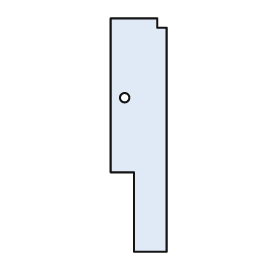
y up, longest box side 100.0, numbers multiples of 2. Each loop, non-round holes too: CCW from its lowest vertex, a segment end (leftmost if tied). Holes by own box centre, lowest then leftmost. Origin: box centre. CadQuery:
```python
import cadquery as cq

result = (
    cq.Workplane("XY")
    .moveTo(-2.0, -50.0)
    .lineTo(12.0, -50.0)
    .lineTo(12.0, 46.0)
    .lineTo(8.0, 46.0)
    .lineTo(8.0, 50.0)
    .lineTo(-12.0, 50.0)
    .lineTo(-12.0, -16.0)
    .lineTo(-2.0, -16.0)
    .close()
    .moveTo(-6.0, 16.0)
    .circle(2.0)
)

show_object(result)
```